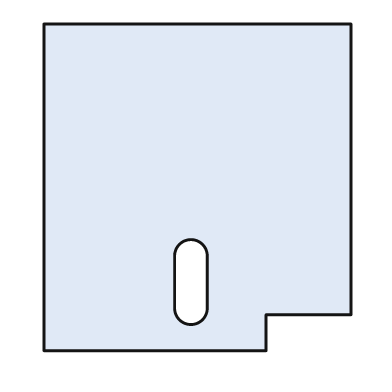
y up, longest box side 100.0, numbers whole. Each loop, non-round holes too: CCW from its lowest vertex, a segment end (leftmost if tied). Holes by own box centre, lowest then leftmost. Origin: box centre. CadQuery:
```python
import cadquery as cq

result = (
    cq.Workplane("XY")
    .moveTo(-47.0, -50.0)
    .lineTo(21.0, -50.0)
    .lineTo(21.0, -39.0)
    .lineTo(47.0, -39.0)
    .lineTo(47.0, 50.0)
    .lineTo(-47.0, 50.0)
    .close()
    .moveTo(-7.0, -37.0)
    .threePointArc((-2.0, -42.0), (3.0, -37.0))
    .lineTo(3.0, -21.0)
    .threePointArc((-2.0, -16.0), (-7.0, -21.0))
    .close()
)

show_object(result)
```